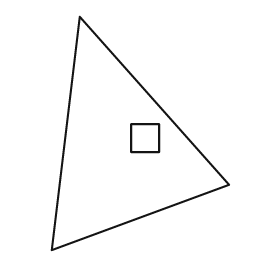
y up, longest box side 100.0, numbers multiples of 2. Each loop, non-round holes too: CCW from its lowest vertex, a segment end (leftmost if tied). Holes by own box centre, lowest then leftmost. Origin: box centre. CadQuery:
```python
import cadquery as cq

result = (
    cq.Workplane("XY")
    .moveTo(-38.0, -50.0)
    .lineTo(38.0, -22.0)
    .lineTo(-26.0, 50.0)
    .close()
    .moveTo(-4.0, -8.0)
    .lineTo(8.0, -8.0)
    .lineTo(8.0, 4.0)
    .lineTo(-4.0, 4.0)
    .close()
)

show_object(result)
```